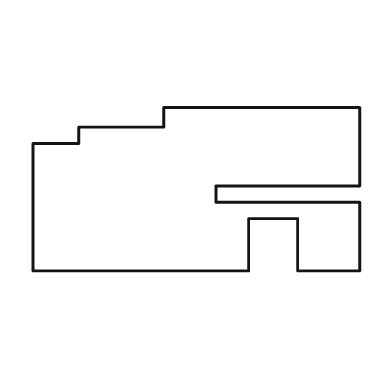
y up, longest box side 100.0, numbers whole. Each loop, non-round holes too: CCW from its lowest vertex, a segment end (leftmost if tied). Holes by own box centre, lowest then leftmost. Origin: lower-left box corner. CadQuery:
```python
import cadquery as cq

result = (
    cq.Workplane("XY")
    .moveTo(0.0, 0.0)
    .lineTo(66.0, 0.0)
    .lineTo(66.0, 16.0)
    .lineTo(81.0, 16.0)
    .lineTo(81.0, 0.0)
    .lineTo(100.0, 0.0)
    .lineTo(100.0, 21.0)
    .lineTo(56.0, 21.0)
    .lineTo(56.0, 26.0)
    .lineTo(100.0, 26.0)
    .lineTo(100.0, 50.0)
    .lineTo(40.0, 50.0)
    .lineTo(40.0, 44.0)
    .lineTo(14.0, 44.0)
    .lineTo(14.0, 39.0)
    .lineTo(0.0, 39.0)
    .close()
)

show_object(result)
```